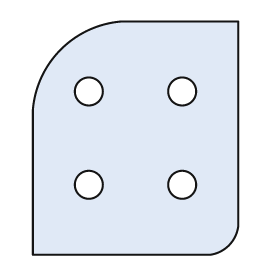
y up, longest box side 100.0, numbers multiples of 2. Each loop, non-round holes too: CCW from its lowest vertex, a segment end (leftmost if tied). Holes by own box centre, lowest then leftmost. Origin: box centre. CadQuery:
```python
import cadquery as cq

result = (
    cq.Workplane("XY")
    .moveTo(-44.0, -50.0)
    .lineTo(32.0, -50.0)
    .threePointArc((40.0, -46.0), (44.0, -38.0))
    .lineTo(44.0, 50.0)
    .lineTo(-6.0, 50.0)
    .threePointArc((-32.0, 38.0), (-44.0, 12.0))
    .close()
    .moveTo(-20.0, -20.0)
    .circle(6.0)
    .moveTo(20.0, -20.0)
    .circle(6.0)
    .moveTo(-20.0, 20.0)
    .circle(6.0)
    .moveTo(20.0, 20.0)
    .circle(6.0)
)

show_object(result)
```